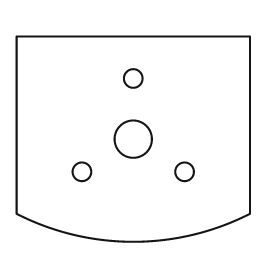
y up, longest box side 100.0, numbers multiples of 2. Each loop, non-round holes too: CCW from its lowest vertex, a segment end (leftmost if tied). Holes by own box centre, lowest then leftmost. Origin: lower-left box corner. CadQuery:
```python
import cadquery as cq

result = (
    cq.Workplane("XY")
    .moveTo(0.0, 12.0)
    .threePointArc((50.0, 0.0), (100.0, 12.0))
    .lineTo(100.0, 88.0)
    .lineTo(0.0, 88.0)
    .close()
    .moveTo(28.0, 30.0)
    .circle(4.0)
    .moveTo(72.0, 30.0)
    .circle(4.0)
    .moveTo(50.0, 44.0)
    .circle(8.0)
    .moveTo(50.0, 70.0)
    .circle(4.0)
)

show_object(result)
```